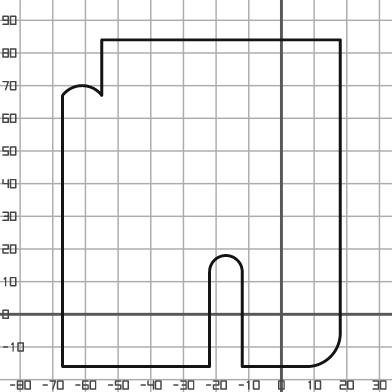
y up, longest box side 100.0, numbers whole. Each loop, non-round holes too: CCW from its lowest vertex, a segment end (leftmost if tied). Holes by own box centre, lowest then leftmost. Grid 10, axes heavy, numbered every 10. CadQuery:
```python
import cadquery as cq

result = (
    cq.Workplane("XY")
    .moveTo(-67.0, -16.0)
    .lineTo(-22.0, -16.0)
    .lineTo(-22.0, 13.0)
    .threePointArc((-17.0, 18.0), (-12.0, 13.0))
    .lineTo(-12.0, -16.0)
    .lineTo(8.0, -16.0)
    .threePointArc((15.0, -13.0), (18.0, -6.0))
    .lineTo(18.0, 84.0)
    .lineTo(-55.0, 84.0)
    .lineTo(-55.0, 67.0)
    .threePointArc((-61.0, 70.0), (-67.0, 67.0))
    .close()
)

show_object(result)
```